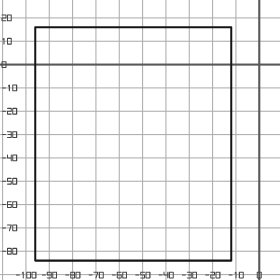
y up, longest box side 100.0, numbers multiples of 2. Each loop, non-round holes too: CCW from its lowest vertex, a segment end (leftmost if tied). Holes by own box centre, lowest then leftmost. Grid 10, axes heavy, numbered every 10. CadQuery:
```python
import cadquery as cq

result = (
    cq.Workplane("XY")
    .moveTo(-96.0, -84.0)
    .lineTo(-12.0, -84.0)
    .lineTo(-12.0, 16.0)
    .lineTo(-96.0, 16.0)
    .close()
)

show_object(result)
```